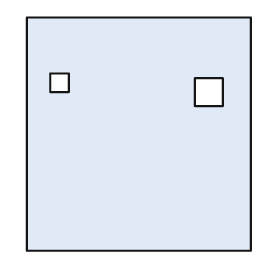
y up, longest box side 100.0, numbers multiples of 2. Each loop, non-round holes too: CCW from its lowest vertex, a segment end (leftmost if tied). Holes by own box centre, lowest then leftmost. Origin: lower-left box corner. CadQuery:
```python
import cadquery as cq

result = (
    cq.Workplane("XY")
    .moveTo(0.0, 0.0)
    .lineTo(96.0, 0.0)
    .lineTo(96.0, 100.0)
    .lineTo(0.0, 100.0)
    .close()
    .moveTo(72.0, 62.0)
    .lineTo(84.0, 62.0)
    .lineTo(84.0, 74.0)
    .lineTo(72.0, 74.0)
    .close()
    .moveTo(10.0, 68.0)
    .lineTo(18.0, 68.0)
    .lineTo(18.0, 76.0)
    .lineTo(10.0, 76.0)
    .close()
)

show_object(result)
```